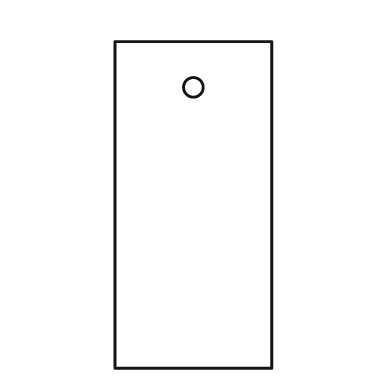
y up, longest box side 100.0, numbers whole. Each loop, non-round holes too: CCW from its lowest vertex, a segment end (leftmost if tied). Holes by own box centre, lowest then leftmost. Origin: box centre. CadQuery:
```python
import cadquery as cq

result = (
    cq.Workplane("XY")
    .moveTo(-24.0, -50.0)
    .lineTo(24.0, -50.0)
    .lineTo(24.0, 50.0)
    .lineTo(-24.0, 50.0)
    .close()
    .moveTo(0.0, 36.0)
    .circle(3.0)
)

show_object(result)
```